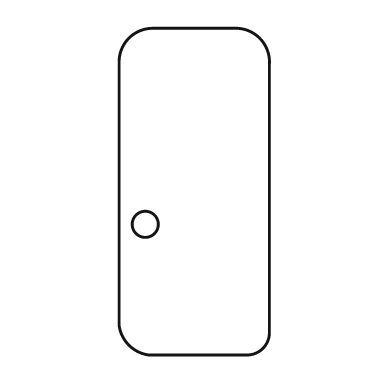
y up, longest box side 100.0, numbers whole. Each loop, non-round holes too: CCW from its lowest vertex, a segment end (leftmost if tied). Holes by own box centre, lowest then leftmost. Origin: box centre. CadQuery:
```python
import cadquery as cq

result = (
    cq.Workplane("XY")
    .moveTo(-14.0, -50.0)
    .lineTo(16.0, -50.0)
    .threePointArc((21.0, -48.0), (23.0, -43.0))
    .lineTo(23.0, 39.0)
    .threePointArc((20.0, 47.0), (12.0, 50.0))
    .lineTo(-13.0, 50.0)
    .threePointArc((-20.0, 47.0), (-23.0, 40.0))
    .lineTo(-23.0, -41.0)
    .threePointArc((-20.0, -47.0), (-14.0, -50.0))
    .close()
    .moveTo(-15.0, -10.0)
    .circle(4.0)
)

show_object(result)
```